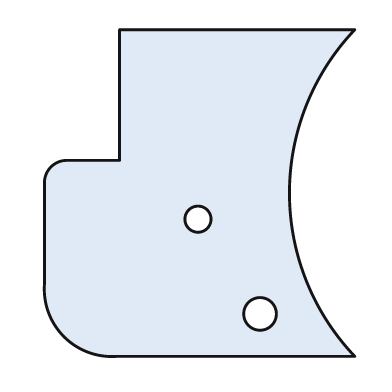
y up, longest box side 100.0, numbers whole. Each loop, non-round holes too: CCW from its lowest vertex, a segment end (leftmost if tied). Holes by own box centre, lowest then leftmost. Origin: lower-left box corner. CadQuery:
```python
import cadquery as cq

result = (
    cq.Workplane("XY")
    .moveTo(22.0, 0.0)
    .lineTo(95.0, 0.0)
    .threePointArc((75.0, 50.0), (95.0, 100.0))
    .lineTo(23.0, 100.0)
    .lineTo(23.0, 60.0)
    .lineTo(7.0, 60.0)
    .threePointArc((2.0, 58.0), (0.0, 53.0))
    .lineTo(0.0, 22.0)
    .threePointArc((6.0, 6.0), (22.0, 0.0))
    .close()
    .moveTo(66.0, 13.0)
    .circle(5.0)
    .moveTo(47.0, 42.0)
    .circle(4.0)
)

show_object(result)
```